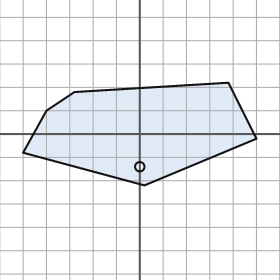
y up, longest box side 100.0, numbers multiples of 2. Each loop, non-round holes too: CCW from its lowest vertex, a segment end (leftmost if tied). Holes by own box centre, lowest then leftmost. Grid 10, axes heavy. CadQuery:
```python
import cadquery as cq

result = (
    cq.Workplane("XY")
    .moveTo(2.0, -22.0)
    .lineTo(50.0, -2.0)
    .lineTo(38.0, 22.0)
    .lineTo(-28.0, 18.0)
    .lineTo(-40.0, 10.0)
    .lineTo(-50.0, -8.0)
    .close()
    .moveTo(0.0, -14.0)
    .circle(2.0)
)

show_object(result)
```